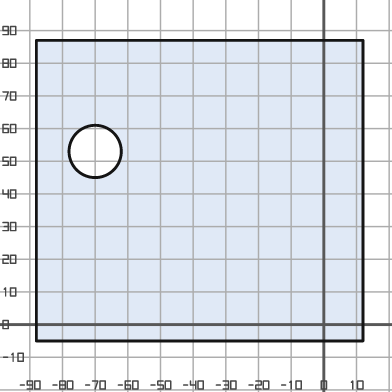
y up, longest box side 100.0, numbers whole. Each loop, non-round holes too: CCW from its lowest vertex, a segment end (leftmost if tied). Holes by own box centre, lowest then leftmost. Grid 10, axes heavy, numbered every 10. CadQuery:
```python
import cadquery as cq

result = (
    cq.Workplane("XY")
    .moveTo(-88.0, -5.0)
    .lineTo(12.0, -5.0)
    .lineTo(12.0, 87.0)
    .lineTo(-88.0, 87.0)
    .close()
    .moveTo(-70.0, 53.0)
    .circle(8.0)
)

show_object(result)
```